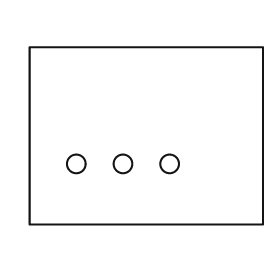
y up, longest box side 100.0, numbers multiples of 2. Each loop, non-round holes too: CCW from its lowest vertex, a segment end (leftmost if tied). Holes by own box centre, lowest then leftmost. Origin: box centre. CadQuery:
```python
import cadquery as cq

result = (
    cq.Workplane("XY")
    .moveTo(-50.0, -38.0)
    .lineTo(50.0, -38.0)
    .lineTo(50.0, 38.0)
    .lineTo(-50.0, 38.0)
    .close()
    .moveTo(-30.0, -12.0)
    .circle(4.0)
    .moveTo(-10.0, -12.0)
    .circle(4.0)
    .moveTo(10.0, -12.0)
    .circle(4.0)
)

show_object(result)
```